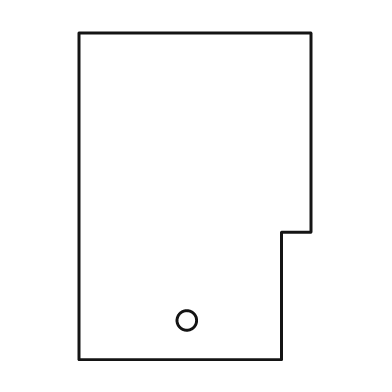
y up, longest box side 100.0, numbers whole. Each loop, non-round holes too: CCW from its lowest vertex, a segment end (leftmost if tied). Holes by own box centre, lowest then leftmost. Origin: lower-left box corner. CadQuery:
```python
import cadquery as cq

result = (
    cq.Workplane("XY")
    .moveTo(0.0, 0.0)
    .lineTo(62.0, 0.0)
    .lineTo(62.0, 39.0)
    .lineTo(71.0, 39.0)
    .lineTo(71.0, 100.0)
    .lineTo(0.0, 100.0)
    .close()
    .moveTo(33.0, 12.0)
    .circle(3.0)
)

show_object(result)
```